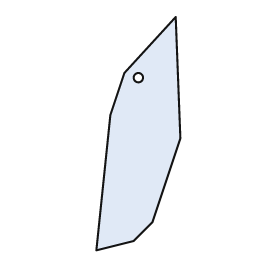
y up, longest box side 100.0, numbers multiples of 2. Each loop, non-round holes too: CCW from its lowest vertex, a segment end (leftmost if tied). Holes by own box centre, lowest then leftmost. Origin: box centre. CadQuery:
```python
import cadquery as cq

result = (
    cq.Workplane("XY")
    .moveTo(-18.0, -50.0)
    .lineTo(-2.0, -46.0)
    .lineTo(6.0, -38.0)
    .lineTo(18.0, -2.0)
    .lineTo(16.0, 50.0)
    .lineTo(-6.0, 26.0)
    .lineTo(-12.0, 8.0)
    .close()
    .moveTo(0.0, 24.0)
    .circle(2.0)
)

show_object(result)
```